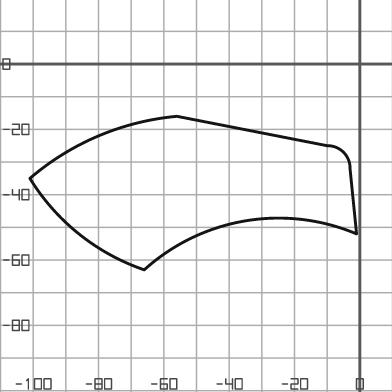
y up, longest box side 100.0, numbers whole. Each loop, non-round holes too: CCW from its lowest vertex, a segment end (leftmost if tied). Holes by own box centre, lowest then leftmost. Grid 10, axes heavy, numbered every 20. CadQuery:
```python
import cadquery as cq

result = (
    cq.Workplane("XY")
    .moveTo(-66.0, -63.0)
    .threePointArc((-35.0, -48.0), (-1.0, -52.0))
    .lineTo(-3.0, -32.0)
    .threePointArc((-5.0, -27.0), (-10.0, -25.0))
    .lineTo(-56.0, -16.0)
    .threePointArc((-80.0, -22.0), (-101.0, -35.0))
    .threePointArc((-86.0, -52.0), (-66.0, -63.0))
    .close()
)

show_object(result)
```